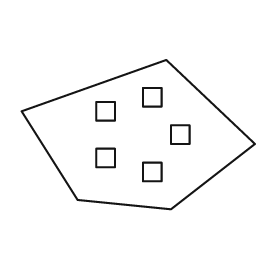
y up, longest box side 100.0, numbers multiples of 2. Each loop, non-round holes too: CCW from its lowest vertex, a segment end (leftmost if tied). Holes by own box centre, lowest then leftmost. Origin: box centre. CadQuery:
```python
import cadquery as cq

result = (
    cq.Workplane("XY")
    .moveTo(14.0, -32.0)
    .lineTo(50.0, -4.0)
    .lineTo(12.0, 32.0)
    .lineTo(-50.0, 10.0)
    .lineTo(-26.0, -28.0)
    .close()
    .moveTo(2.0, -20.0)
    .lineTo(10.0, -20.0)
    .lineTo(10.0, -12.0)
    .lineTo(2.0, -12.0)
    .close()
    .moveTo(-18.0, -14.0)
    .lineTo(-10.0, -14.0)
    .lineTo(-10.0, -6.0)
    .lineTo(-18.0, -6.0)
    .close()
    .moveTo(14.0, -4.0)
    .lineTo(22.0, -4.0)
    .lineTo(22.0, 4.0)
    .lineTo(14.0, 4.0)
    .close()
    .moveTo(-18.0, 6.0)
    .lineTo(-10.0, 6.0)
    .lineTo(-10.0, 14.0)
    .lineTo(-18.0, 14.0)
    .close()
    .moveTo(2.0, 12.0)
    .lineTo(10.0, 12.0)
    .lineTo(10.0, 20.0)
    .lineTo(2.0, 20.0)
    .close()
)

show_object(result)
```